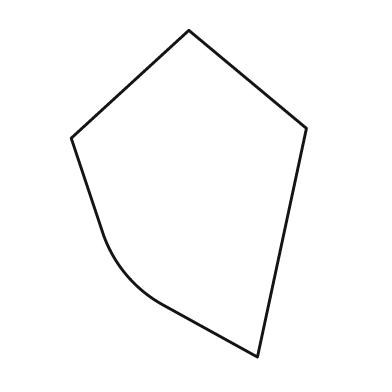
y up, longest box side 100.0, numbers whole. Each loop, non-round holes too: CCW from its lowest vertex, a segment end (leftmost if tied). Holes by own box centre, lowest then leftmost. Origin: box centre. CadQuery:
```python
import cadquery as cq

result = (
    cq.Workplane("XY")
    .moveTo(21.0, -50.0)
    .lineTo(36.0, 20.0)
    .lineTo(0.0, 50.0)
    .lineTo(-36.0, 17.0)
    .lineTo(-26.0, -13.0)
    .threePointArc((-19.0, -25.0), (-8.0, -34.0))
    .close()
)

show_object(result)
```